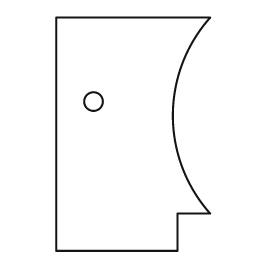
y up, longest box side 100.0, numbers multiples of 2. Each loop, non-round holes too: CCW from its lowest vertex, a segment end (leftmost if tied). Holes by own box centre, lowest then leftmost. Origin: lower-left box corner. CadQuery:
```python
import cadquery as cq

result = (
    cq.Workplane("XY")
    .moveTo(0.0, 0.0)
    .lineTo(52.0, 0.0)
    .lineTo(52.0, 16.0)
    .lineTo(66.0, 16.0)
    .threePointArc((50.0, 58.0), (66.0, 100.0))
    .lineTo(0.0, 100.0)
    .close()
    .moveTo(16.0, 64.0)
    .circle(4.0)
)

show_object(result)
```